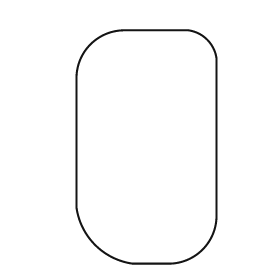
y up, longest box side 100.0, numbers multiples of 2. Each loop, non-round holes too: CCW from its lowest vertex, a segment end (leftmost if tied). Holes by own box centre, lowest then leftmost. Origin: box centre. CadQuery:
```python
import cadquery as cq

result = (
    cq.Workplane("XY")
    .moveTo(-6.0, -50.0)
    .lineTo(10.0, -50.0)
    .threePointArc((24.0, -44.0), (30.0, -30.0))
    .lineTo(30.0, 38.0)
    .threePointArc((26.0, 46.0), (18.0, 50.0))
    .lineTo(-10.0, 50.0)
    .threePointArc((-24.0, 44.0), (-30.0, 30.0))
    .lineTo(-30.0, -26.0)
    .threePointArc((-22.0, -42.0), (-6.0, -50.0))
    .close()
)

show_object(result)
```